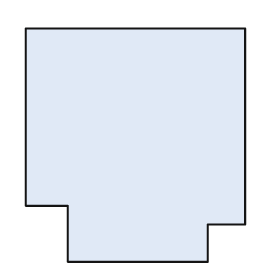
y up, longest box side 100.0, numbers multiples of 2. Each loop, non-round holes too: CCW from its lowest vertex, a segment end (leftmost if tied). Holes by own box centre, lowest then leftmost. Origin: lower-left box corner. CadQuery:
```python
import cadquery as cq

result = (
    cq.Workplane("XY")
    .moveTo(18.0, 0.0)
    .lineTo(78.0, 0.0)
    .lineTo(78.0, 16.0)
    .lineTo(94.0, 16.0)
    .lineTo(94.0, 100.0)
    .lineTo(0.0, 100.0)
    .lineTo(0.0, 24.0)
    .lineTo(18.0, 24.0)
    .close()
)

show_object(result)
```